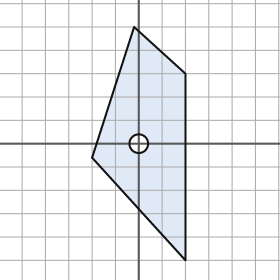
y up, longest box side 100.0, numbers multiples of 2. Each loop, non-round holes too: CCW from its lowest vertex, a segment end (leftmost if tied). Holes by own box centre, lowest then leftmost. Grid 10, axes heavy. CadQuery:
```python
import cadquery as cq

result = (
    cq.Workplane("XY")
    .moveTo(20.0, -50.0)
    .lineTo(20.0, 30.0)
    .lineTo(-2.0, 50.0)
    .lineTo(-20.0, -6.0)
    .close()
    .moveTo(0.0, 0.0)
    .circle(4.0)
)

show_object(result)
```